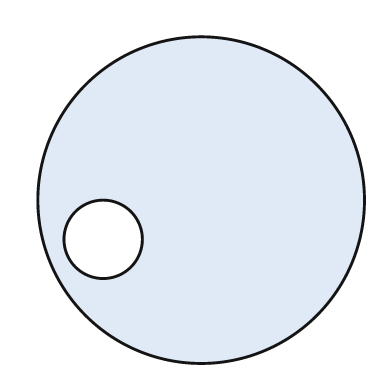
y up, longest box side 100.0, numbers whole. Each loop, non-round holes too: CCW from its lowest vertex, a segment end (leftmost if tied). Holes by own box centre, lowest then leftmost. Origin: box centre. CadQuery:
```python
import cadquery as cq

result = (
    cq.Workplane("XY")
    .moveTo(0.0, 0.0)
    .circle(50.0)
    .moveTo(-30.0, -12.0)
    .circle(12.0)
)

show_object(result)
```